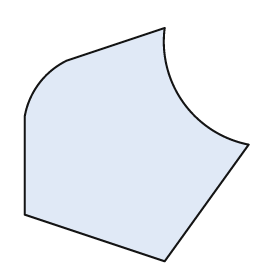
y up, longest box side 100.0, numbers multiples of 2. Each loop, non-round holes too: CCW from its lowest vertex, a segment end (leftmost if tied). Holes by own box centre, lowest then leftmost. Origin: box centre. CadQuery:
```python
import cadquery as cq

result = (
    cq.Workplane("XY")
    .moveTo(12.0, -50.0)
    .lineTo(48.0, 0.0)
    .threePointArc((20.0, 18.0), (12.0, 50.0))
    .lineTo(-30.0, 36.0)
    .threePointArc((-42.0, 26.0), (-48.0, 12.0))
    .lineTo(-48.0, -30.0)
    .close()
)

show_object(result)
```